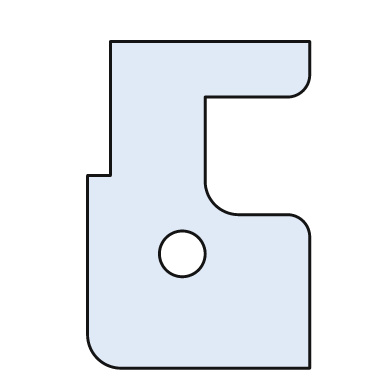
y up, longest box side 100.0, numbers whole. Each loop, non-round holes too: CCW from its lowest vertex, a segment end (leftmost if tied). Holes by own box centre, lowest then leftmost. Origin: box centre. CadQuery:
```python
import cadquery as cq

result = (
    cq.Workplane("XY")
    .moveTo(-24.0, -50.0)
    .lineTo(34.0, -50.0)
    .lineTo(34.0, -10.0)
    .threePointArc((32.0, -5.0), (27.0, -3.0))
    .lineTo(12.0, -3.0)
    .threePointArc((5.0, 0.0), (2.0, 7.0))
    .lineTo(2.0, 33.0)
    .lineTo(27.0, 33.0)
    .threePointArc((32.0, 35.0), (34.0, 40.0))
    .lineTo(34.0, 50.0)
    .lineTo(-27.0, 50.0)
    .lineTo(-27.0, 9.0)
    .lineTo(-34.0, 9.0)
    .lineTo(-34.0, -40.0)
    .threePointArc((-31.0, -47.0), (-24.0, -50.0))
    .close()
    .moveTo(-5.0, -15.0)
    .circle(7.0)
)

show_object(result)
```